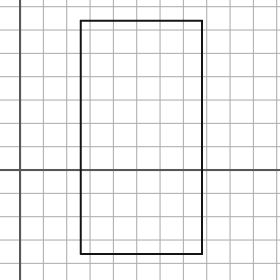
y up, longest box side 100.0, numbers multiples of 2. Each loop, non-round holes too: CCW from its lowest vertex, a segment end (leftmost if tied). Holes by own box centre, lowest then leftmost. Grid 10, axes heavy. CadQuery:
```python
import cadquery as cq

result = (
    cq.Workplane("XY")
    .moveTo(26.0, -36.0)
    .lineTo(78.0, -36.0)
    .lineTo(78.0, 64.0)
    .lineTo(26.0, 64.0)
    .close()
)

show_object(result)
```